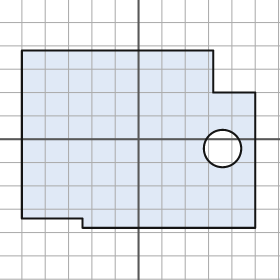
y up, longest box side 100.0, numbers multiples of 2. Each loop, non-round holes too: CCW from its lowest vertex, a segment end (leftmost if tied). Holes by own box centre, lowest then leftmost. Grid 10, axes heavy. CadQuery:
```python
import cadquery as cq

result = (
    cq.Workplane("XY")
    .moveTo(-24.0, -38.0)
    .lineTo(50.0, -38.0)
    .lineTo(50.0, 20.0)
    .lineTo(32.0, 20.0)
    .lineTo(32.0, 38.0)
    .lineTo(-50.0, 38.0)
    .lineTo(-50.0, -34.0)
    .lineTo(-24.0, -34.0)
    .close()
    .moveTo(36.0, -4.0)
    .circle(8.0)
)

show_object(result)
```